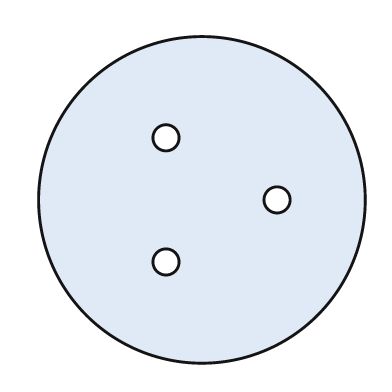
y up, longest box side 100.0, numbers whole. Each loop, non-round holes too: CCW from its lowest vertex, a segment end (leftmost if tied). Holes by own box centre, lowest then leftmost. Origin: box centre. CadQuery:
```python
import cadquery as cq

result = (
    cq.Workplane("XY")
    .moveTo(0.0, 0.0)
    .circle(50.0)
    .moveTo(-11.0, -19.0)
    .circle(4.0)
    .moveTo(23.0, 0.0)
    .circle(4.0)
    .moveTo(-11.0, 19.0)
    .circle(4.0)
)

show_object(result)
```